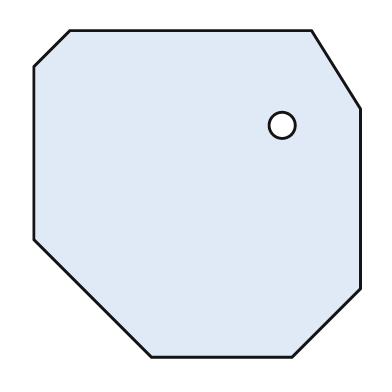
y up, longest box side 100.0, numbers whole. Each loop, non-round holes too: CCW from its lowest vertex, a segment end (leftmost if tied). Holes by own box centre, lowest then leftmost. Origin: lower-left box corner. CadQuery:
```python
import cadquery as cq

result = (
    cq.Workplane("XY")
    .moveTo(36.0, 0.0)
    .lineTo(79.0, 0.0)
    .lineTo(100.0, 21.0)
    .lineTo(100.0, 76.0)
    .lineTo(85.0, 100.0)
    .lineTo(11.0, 100.0)
    .lineTo(0.0, 89.0)
    .lineTo(0.0, 36.0)
    .close()
    .moveTo(76.0, 71.0)
    .circle(4.0)
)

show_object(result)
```